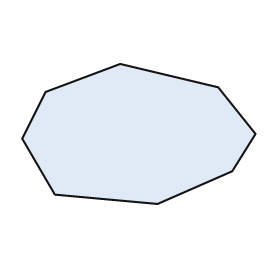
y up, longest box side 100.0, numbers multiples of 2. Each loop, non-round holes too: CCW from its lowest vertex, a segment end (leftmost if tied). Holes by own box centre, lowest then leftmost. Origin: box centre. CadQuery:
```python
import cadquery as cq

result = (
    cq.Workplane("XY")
    .moveTo(8.0, -30.0)
    .lineTo(40.0, -16.0)
    .lineTo(50.0, 0.0)
    .lineTo(34.0, 20.0)
    .lineTo(-8.0, 30.0)
    .lineTo(-40.0, 18.0)
    .lineTo(-50.0, -2.0)
    .lineTo(-36.0, -26.0)
    .close()
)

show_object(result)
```